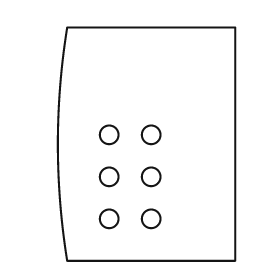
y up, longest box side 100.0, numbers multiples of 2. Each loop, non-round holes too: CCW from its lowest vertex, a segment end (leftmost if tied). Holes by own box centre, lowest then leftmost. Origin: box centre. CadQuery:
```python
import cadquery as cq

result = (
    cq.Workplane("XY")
    .moveTo(-34.0, -50.0)
    .lineTo(38.0, -50.0)
    .lineTo(38.0, 50.0)
    .lineTo(-34.0, 50.0)
    .threePointArc((-38.0, 0.0), (-34.0, -50.0))
    .close()
    .moveTo(-16.0, -32.0)
    .circle(4.0)
    .moveTo(2.0, -32.0)
    .circle(4.0)
    .moveTo(-16.0, -14.0)
    .circle(4.0)
    .moveTo(2.0, -14.0)
    .circle(4.0)
    .moveTo(-16.0, 4.0)
    .circle(4.0)
    .moveTo(2.0, 4.0)
    .circle(4.0)
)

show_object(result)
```